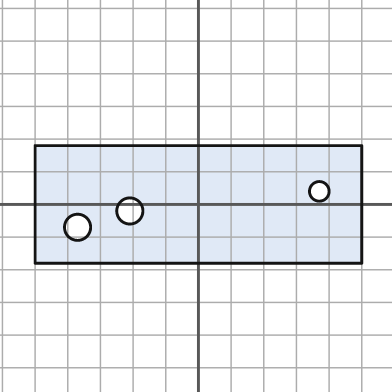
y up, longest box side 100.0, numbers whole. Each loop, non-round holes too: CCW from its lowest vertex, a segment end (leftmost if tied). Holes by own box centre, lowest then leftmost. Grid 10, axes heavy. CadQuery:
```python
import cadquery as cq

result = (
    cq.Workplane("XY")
    .moveTo(-50.0, -18.0)
    .lineTo(50.0, -18.0)
    .lineTo(50.0, 18.0)
    .lineTo(-50.0, 18.0)
    .close()
    .moveTo(-37.0, -7.0)
    .circle(4.0)
    .moveTo(-21.0, -2.0)
    .circle(4.0)
    .moveTo(37.0, 4.0)
    .circle(3.0)
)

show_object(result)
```